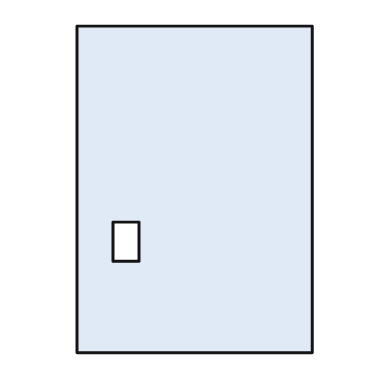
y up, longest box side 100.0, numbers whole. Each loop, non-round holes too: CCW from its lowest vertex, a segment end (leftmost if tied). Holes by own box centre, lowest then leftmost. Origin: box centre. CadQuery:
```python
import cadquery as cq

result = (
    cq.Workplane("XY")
    .moveTo(-36.0, -50.0)
    .lineTo(36.0, -50.0)
    .lineTo(36.0, 50.0)
    .lineTo(-36.0, 50.0)
    .close()
    .moveTo(-25.0, -22.0)
    .lineTo(-17.0, -22.0)
    .lineTo(-17.0, -10.0)
    .lineTo(-25.0, -10.0)
    .close()
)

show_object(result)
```